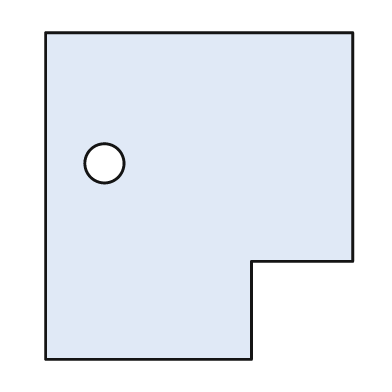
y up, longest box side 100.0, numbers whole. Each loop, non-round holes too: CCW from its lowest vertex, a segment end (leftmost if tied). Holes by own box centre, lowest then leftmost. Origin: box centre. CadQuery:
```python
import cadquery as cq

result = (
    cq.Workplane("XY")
    .moveTo(-47.0, -50.0)
    .lineTo(16.0, -50.0)
    .lineTo(16.0, -20.0)
    .lineTo(47.0, -20.0)
    .lineTo(47.0, 50.0)
    .lineTo(-47.0, 50.0)
    .close()
    .moveTo(-29.0, 10.0)
    .circle(6.0)
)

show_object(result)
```